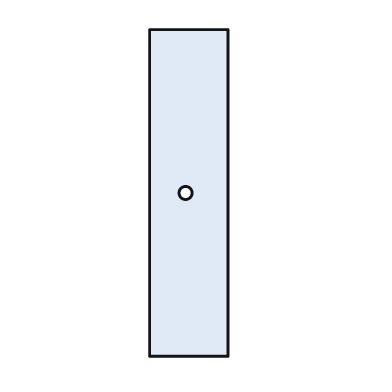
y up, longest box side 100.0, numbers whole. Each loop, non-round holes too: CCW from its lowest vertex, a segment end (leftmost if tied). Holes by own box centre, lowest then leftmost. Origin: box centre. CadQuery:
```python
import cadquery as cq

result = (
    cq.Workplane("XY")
    .moveTo(-12.0, -50.0)
    .lineTo(12.0, -50.0)
    .lineTo(12.0, 50.0)
    .lineTo(-12.0, 50.0)
    .close()
    .moveTo(-1.0, 0.0)
    .circle(2.0)
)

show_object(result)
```